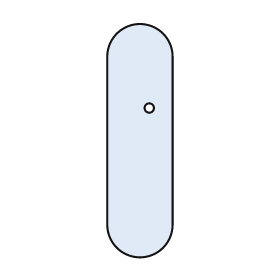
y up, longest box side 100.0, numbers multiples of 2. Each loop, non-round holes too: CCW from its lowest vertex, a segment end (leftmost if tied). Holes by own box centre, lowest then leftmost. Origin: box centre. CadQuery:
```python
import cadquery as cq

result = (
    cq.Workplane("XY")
    .moveTo(-14.0, -36.0)
    .threePointArc((0.0, -50.0), (14.0, -36.0))
    .lineTo(14.0, 36.0)
    .threePointArc((0.0, 50.0), (-14.0, 36.0))
    .close()
    .moveTo(4.0, 14.0)
    .circle(2.0)
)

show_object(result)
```